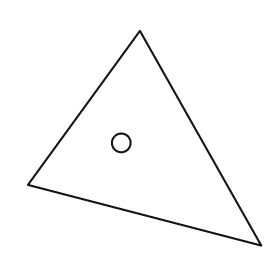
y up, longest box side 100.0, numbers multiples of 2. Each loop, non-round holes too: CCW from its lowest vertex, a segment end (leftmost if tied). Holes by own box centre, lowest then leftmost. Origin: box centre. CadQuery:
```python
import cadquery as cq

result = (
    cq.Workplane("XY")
    .moveTo(50.0, -46.0)
    .lineTo(-2.0, 46.0)
    .lineTo(-50.0, -20.0)
    .close()
    .moveTo(-10.0, -2.0)
    .circle(4.0)
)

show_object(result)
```